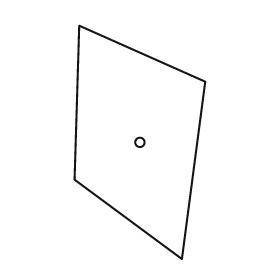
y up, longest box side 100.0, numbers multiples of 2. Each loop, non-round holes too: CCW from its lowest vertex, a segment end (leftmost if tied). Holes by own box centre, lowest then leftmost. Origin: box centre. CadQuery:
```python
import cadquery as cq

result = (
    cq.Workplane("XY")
    .moveTo(18.0, -50.0)
    .lineTo(28.0, 26.0)
    .lineTo(-26.0, 50.0)
    .lineTo(-28.0, -16.0)
    .close()
    .moveTo(0.0, 0.0)
    .circle(2.0)
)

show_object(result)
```